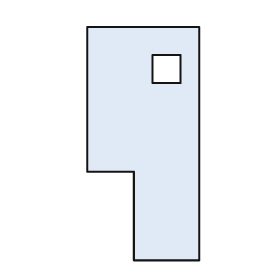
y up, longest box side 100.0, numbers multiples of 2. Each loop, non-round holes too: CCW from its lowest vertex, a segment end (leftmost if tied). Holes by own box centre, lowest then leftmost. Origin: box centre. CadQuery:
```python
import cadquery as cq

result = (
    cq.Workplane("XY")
    .moveTo(-4.0, -50.0)
    .lineTo(24.0, -50.0)
    .lineTo(24.0, 50.0)
    .lineTo(-24.0, 50.0)
    .lineTo(-24.0, -12.0)
    .lineTo(-4.0, -12.0)
    .close()
    .moveTo(4.0, 26.0)
    .lineTo(16.0, 26.0)
    .lineTo(16.0, 38.0)
    .lineTo(4.0, 38.0)
    .close()
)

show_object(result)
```